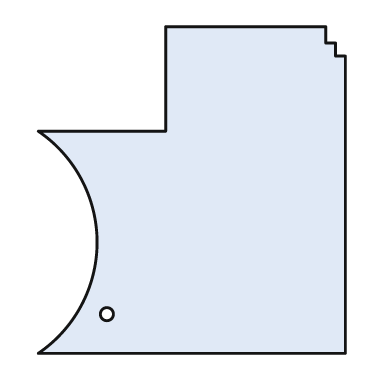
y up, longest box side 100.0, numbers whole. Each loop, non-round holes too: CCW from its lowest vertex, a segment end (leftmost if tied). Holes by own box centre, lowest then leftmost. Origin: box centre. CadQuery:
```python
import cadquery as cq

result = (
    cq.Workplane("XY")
    .moveTo(-47.0, -50.0)
    .lineTo(47.0, -50.0)
    .lineTo(47.0, 41.0)
    .lineTo(44.0, 41.0)
    .lineTo(44.0, 45.0)
    .lineTo(41.0, 45.0)
    .lineTo(41.0, 50.0)
    .lineTo(-8.0, 50.0)
    .lineTo(-8.0, 18.0)
    .lineTo(-47.0, 18.0)
    .threePointArc((-29.0, -16.0), (-47.0, -50.0))
    .close()
    .moveTo(-26.0, -38.0)
    .circle(2.0)
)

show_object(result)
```